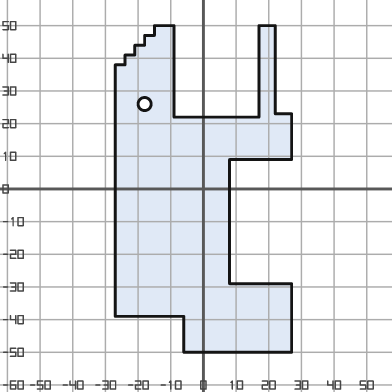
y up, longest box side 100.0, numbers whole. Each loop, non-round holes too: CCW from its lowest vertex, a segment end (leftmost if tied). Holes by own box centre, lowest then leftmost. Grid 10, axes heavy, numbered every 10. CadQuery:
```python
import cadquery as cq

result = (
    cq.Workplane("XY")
    .moveTo(-6.0, -50.0)
    .lineTo(27.0, -50.0)
    .lineTo(27.0, -29.0)
    .lineTo(8.0, -29.0)
    .lineTo(8.0, 9.0)
    .lineTo(27.0, 9.0)
    .lineTo(27.0, 23.0)
    .lineTo(22.0, 23.0)
    .lineTo(22.0, 50.0)
    .lineTo(17.0, 50.0)
    .lineTo(17.0, 22.0)
    .lineTo(-9.0, 22.0)
    .lineTo(-9.0, 50.0)
    .lineTo(-15.0, 50.0)
    .lineTo(-15.0, 47.0)
    .lineTo(-18.0, 47.0)
    .lineTo(-18.0, 44.0)
    .lineTo(-21.0, 44.0)
    .lineTo(-21.0, 41.0)
    .lineTo(-24.0, 41.0)
    .lineTo(-24.0, 38.0)
    .lineTo(-27.0, 38.0)
    .lineTo(-27.0, -39.0)
    .lineTo(-6.0, -39.0)
    .close()
    .moveTo(-18.0, 26.0)
    .circle(2.0)
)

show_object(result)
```